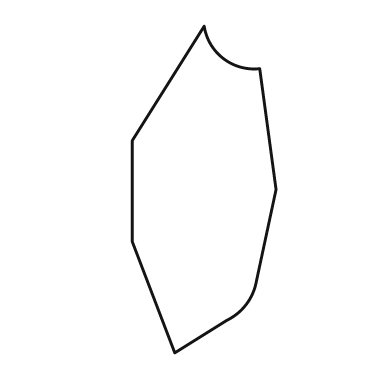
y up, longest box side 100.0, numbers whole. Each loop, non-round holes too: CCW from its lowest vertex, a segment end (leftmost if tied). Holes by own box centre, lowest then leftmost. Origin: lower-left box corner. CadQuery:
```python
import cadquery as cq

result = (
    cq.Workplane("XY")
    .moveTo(13.0, 0.0)
    .lineTo(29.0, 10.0)
    .threePointArc((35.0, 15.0), (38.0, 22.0))
    .lineTo(44.0, 50.0)
    .lineTo(39.0, 87.0)
    .threePointArc((28.0, 90.0), (22.0, 100.0))
    .lineTo(0.0, 65.0)
    .lineTo(0.0, 34.0)
    .close()
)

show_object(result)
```